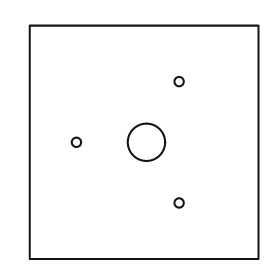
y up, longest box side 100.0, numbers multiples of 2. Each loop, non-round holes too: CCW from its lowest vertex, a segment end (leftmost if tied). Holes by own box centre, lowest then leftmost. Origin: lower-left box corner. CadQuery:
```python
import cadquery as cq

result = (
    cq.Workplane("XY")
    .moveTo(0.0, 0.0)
    .lineTo(98.0, 0.0)
    .lineTo(98.0, 100.0)
    .lineTo(0.0, 100.0)
    .close()
    .moveTo(64.0, 24.0)
    .circle(2.0)
    .moveTo(20.0, 50.0)
    .circle(2.0)
    .moveTo(50.0, 50.0)
    .circle(8.0)
    .moveTo(64.0, 76.0)
    .circle(2.0)
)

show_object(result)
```